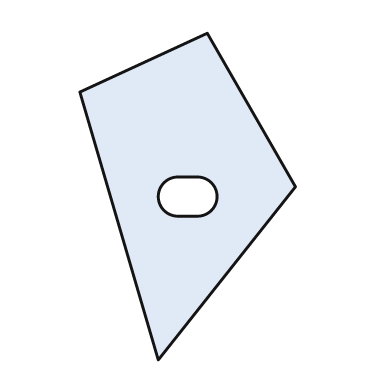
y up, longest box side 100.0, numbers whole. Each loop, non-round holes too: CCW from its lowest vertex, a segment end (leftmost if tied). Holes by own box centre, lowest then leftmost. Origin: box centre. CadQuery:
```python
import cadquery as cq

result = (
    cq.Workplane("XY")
    .moveTo(-9.0, -50.0)
    .lineTo(33.0, 3.0)
    .lineTo(6.0, 50.0)
    .lineTo(-33.0, 32.0)
    .close()
    .moveTo(-3.0, -6.0)
    .lineTo(3.0, -6.0)
    .threePointArc((9.0, 0.0), (3.0, 6.0))
    .lineTo(-3.0, 6.0)
    .threePointArc((-9.0, 0.0), (-3.0, -6.0))
    .close()
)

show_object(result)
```